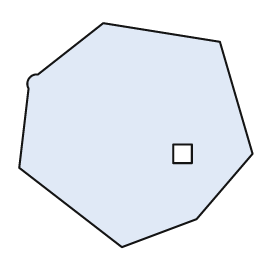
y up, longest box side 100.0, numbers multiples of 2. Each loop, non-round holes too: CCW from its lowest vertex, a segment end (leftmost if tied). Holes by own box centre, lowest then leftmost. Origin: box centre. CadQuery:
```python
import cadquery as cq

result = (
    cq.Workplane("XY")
    .moveTo(-6.0, -48.0)
    .lineTo(26.0, -36.0)
    .lineTo(50.0, -8.0)
    .lineTo(36.0, 40.0)
    .lineTo(-14.0, 48.0)
    .lineTo(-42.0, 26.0)
    .threePointArc((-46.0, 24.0), (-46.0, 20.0))
    .lineTo(-50.0, -14.0)
    .close()
    .moveTo(16.0, -12.0)
    .lineTo(24.0, -12.0)
    .lineTo(24.0, -4.0)
    .lineTo(16.0, -4.0)
    .close()
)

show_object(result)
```